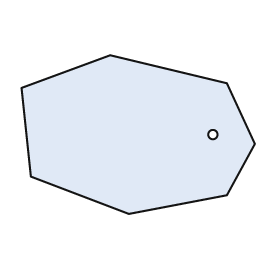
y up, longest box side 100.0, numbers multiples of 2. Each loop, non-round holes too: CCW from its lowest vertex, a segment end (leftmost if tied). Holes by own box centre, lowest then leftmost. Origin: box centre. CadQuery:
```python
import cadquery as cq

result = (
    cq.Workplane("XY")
    .moveTo(-4.0, -34.0)
    .lineTo(38.0, -26.0)
    .lineTo(50.0, -4.0)
    .lineTo(38.0, 22.0)
    .lineTo(-12.0, 34.0)
    .lineTo(-50.0, 20.0)
    .lineTo(-46.0, -18.0)
    .close()
    .moveTo(32.0, 0.0)
    .circle(2.0)
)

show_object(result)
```